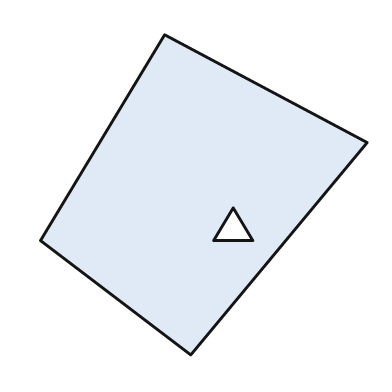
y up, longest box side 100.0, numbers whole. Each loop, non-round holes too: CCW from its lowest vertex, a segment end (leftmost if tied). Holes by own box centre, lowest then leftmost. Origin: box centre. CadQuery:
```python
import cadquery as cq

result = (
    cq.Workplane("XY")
    .moveTo(-4.0, -49.0)
    .lineTo(50.0, 16.0)
    .lineTo(-12.0, 49.0)
    .lineTo(-50.0, -14.0)
    .close()
    .moveTo(3.0, -14.0)
    .lineTo(15.0, -14.0)
    .lineTo(9.0, -4.0)
    .close()
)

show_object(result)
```